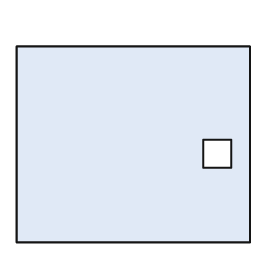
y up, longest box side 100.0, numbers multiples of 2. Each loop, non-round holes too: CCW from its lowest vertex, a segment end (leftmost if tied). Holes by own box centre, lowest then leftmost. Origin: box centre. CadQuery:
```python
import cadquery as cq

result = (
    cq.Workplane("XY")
    .moveTo(-50.0, -42.0)
    .lineTo(50.0, -42.0)
    .lineTo(50.0, 42.0)
    .lineTo(-50.0, 42.0)
    .close()
    .moveTo(30.0, -10.0)
    .lineTo(42.0, -10.0)
    .lineTo(42.0, 2.0)
    .lineTo(30.0, 2.0)
    .close()
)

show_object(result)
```